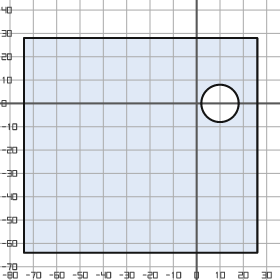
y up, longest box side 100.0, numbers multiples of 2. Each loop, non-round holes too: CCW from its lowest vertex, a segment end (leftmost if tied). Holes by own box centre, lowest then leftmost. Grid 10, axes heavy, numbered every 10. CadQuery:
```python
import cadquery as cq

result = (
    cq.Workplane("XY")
    .moveTo(-74.0, -64.0)
    .lineTo(26.0, -64.0)
    .lineTo(26.0, 28.0)
    .lineTo(-74.0, 28.0)
    .close()
    .moveTo(10.0, 0.0)
    .circle(8.0)
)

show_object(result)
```